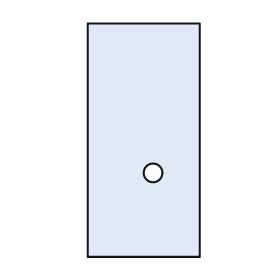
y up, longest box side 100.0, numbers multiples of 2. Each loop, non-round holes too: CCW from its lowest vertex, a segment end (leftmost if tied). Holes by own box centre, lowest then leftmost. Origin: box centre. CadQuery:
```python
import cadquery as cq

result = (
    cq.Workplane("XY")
    .moveTo(-24.0, -50.0)
    .lineTo(24.0, -50.0)
    .lineTo(24.0, 50.0)
    .lineTo(-24.0, 50.0)
    .close()
    .moveTo(4.0, -14.0)
    .circle(4.0)
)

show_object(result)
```